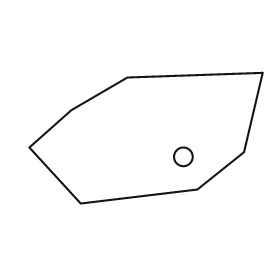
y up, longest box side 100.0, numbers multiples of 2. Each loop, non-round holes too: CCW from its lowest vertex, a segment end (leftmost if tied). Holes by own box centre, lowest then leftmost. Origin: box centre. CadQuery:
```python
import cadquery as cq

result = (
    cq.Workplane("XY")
    .moveTo(-28.0, -28.0)
    .lineTo(22.0, -22.0)
    .lineTo(42.0, -6.0)
    .lineTo(50.0, 28.0)
    .lineTo(-8.0, 26.0)
    .lineTo(-32.0, 12.0)
    .lineTo(-50.0, -4.0)
    .close()
    .moveTo(16.0, -8.0)
    .circle(4.0)
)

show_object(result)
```